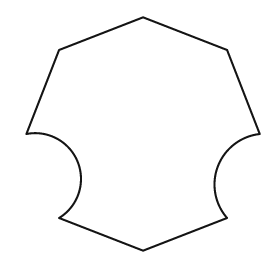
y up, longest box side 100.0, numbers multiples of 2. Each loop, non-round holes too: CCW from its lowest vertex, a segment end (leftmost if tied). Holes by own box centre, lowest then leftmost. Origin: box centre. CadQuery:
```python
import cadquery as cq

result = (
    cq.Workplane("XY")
    .moveTo(0.0, -50.0)
    .lineTo(36.0, -36.0)
    .threePointArc((32.0, -14.0), (50.0, 0.0))
    .lineTo(36.0, 36.0)
    .lineTo(0.0, 50.0)
    .lineTo(-36.0, 36.0)
    .lineTo(-50.0, 0.0)
    .threePointArc((-28.0, -12.0), (-36.0, -36.0))
    .close()
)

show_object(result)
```